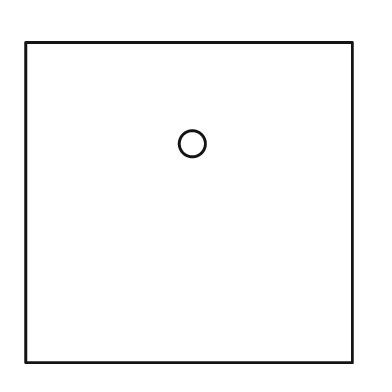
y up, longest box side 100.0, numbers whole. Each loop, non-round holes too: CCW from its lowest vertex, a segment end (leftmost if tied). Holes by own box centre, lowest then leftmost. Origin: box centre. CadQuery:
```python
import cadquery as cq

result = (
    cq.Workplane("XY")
    .moveTo(-50.0, -49.0)
    .lineTo(50.0, -49.0)
    .lineTo(50.0, 49.0)
    .lineTo(-50.0, 49.0)
    .close()
    .moveTo(1.0, 18.0)
    .circle(4.0)
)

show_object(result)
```